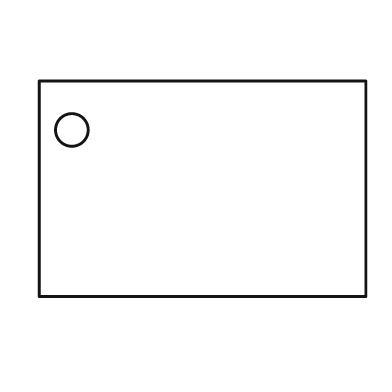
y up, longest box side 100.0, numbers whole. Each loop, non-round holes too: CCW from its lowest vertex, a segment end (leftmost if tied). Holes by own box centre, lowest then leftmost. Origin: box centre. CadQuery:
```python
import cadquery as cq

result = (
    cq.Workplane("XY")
    .moveTo(-50.0, -33.0)
    .lineTo(50.0, -33.0)
    .lineTo(50.0, 33.0)
    .lineTo(-50.0, 33.0)
    .close()
    .moveTo(-40.0, 18.0)
    .circle(5.0)
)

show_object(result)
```